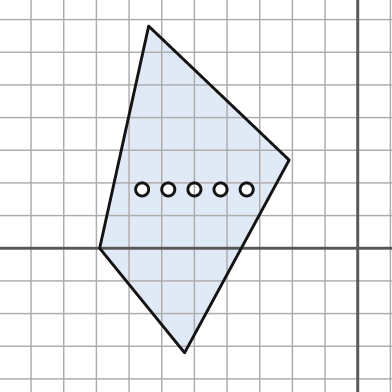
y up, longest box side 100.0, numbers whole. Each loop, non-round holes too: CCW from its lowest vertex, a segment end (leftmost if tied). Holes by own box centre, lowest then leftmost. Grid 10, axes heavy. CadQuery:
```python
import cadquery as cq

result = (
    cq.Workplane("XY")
    .moveTo(-53.0, -32.0)
    .lineTo(-21.0, 27.0)
    .lineTo(-64.0, 68.0)
    .lineTo(-79.0, 0.0)
    .close()
    .moveTo(-66.0, 18.0)
    .circle(2.0)
    .moveTo(-58.0, 18.0)
    .circle(2.0)
    .moveTo(-50.0, 18.0)
    .circle(2.0)
    .moveTo(-42.0, 18.0)
    .circle(2.0)
    .moveTo(-34.0, 18.0)
    .circle(2.0)
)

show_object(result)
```